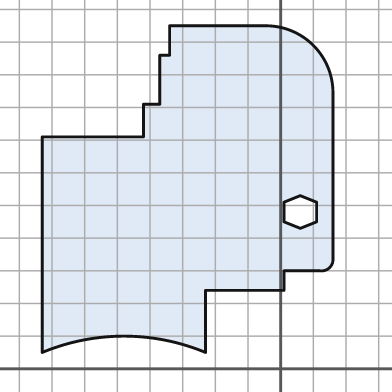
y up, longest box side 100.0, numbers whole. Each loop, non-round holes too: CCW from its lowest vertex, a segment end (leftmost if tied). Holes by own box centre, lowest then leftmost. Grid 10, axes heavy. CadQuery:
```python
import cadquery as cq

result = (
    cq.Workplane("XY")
    .moveTo(-73.0, 5.0)
    .threePointArc((-48.0, 10.0), (-23.0, 5.0))
    .lineTo(-23.0, 24.0)
    .lineTo(1.0, 24.0)
    .lineTo(1.0, 30.0)
    .lineTo(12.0, 30.0)
    .threePointArc((15.0, 31.0), (16.0, 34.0))
    .lineTo(16.0, 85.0)
    .threePointArc((10.0, 99.0), (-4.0, 105.0))
    .lineTo(-34.0, 105.0)
    .lineTo(-34.0, 96.0)
    .lineTo(-37.0, 96.0)
    .lineTo(-37.0, 81.0)
    .lineTo(-42.0, 81.0)
    .lineTo(-42.0, 71.0)
    .lineTo(-73.0, 71.0)
    .close()
    .moveTo(6.0, 43.0)
    .lineTo(11.0, 45.0)
    .lineTo(11.0, 51.0)
    .lineTo(6.0, 53.0)
    .lineTo(1.0, 51.0)
    .lineTo(1.0, 45.0)
    .close()
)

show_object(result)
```